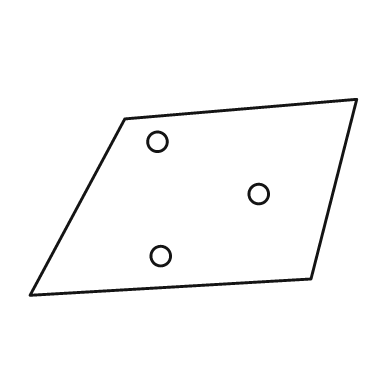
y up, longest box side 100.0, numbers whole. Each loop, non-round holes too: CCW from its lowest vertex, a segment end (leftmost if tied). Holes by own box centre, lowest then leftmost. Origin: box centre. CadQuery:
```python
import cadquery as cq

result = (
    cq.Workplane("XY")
    .moveTo(-50.0, -30.0)
    .lineTo(36.0, -25.0)
    .lineTo(50.0, 30.0)
    .lineTo(-21.0, 24.0)
    .close()
    .moveTo(-10.0, -18.0)
    .circle(3.0)
    .moveTo(20.0, 1.0)
    .circle(3.0)
    .moveTo(-11.0, 17.0)
    .circle(3.0)
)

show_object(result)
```